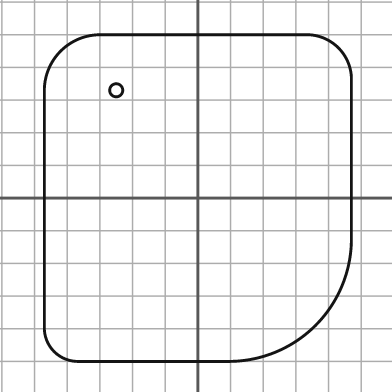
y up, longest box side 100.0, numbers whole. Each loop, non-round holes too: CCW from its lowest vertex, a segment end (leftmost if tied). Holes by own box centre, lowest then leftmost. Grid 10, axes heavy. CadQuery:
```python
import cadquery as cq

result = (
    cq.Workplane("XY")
    .moveTo(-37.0, -50.0)
    .lineTo(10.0, -50.0)
    .threePointArc((36.0, -39.0), (47.0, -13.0))
    .lineTo(47.0, 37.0)
    .threePointArc((43.0, 46.0), (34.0, 50.0))
    .lineTo(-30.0, 50.0)
    .threePointArc((-42.0, 45.0), (-47.0, 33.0))
    .lineTo(-47.0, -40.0)
    .threePointArc((-44.0, -47.0), (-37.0, -50.0))
    .close()
    .moveTo(-25.0, 33.0)
    .circle(2.0)
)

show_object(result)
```